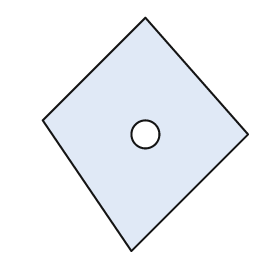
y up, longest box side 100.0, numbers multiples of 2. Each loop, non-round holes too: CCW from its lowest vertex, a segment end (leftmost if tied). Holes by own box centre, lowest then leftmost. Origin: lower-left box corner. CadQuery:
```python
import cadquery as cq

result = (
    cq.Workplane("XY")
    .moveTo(38.0, 0.0)
    .lineTo(88.0, 50.0)
    .lineTo(44.0, 100.0)
    .lineTo(0.0, 56.0)
    .close()
    .moveTo(44.0, 50.0)
    .circle(6.0)
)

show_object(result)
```